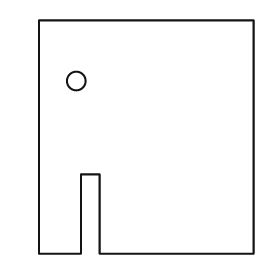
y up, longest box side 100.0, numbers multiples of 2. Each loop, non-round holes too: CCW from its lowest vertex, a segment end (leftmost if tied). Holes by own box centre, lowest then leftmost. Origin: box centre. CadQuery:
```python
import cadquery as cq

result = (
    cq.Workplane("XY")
    .moveTo(-46.0, -50.0)
    .lineTo(-28.0, -50.0)
    .lineTo(-28.0, -16.0)
    .lineTo(-20.0, -16.0)
    .lineTo(-20.0, -50.0)
    .lineTo(46.0, -50.0)
    .lineTo(46.0, 50.0)
    .lineTo(-46.0, 50.0)
    .close()
    .moveTo(-30.0, 24.0)
    .circle(4.0)
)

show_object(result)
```